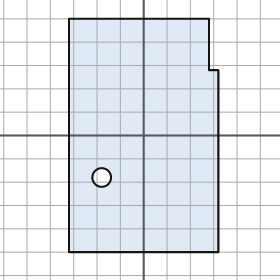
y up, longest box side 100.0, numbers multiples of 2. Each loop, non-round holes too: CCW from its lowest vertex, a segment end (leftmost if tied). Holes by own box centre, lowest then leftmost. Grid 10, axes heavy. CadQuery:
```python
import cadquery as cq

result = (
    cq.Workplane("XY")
    .moveTo(-32.0, -50.0)
    .lineTo(32.0, -50.0)
    .lineTo(32.0, 28.0)
    .lineTo(28.0, 28.0)
    .lineTo(28.0, 50.0)
    .lineTo(-32.0, 50.0)
    .close()
    .moveTo(-18.0, -18.0)
    .circle(4.0)
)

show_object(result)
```